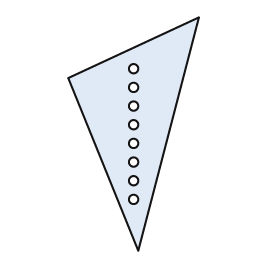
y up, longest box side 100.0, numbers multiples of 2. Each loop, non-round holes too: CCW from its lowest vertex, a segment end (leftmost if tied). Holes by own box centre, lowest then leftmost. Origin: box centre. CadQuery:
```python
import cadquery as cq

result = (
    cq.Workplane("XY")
    .moveTo(2.0, -50.0)
    .lineTo(28.0, 50.0)
    .lineTo(-28.0, 24.0)
    .close()
    .moveTo(0.0, -28.0)
    .circle(2.0)
    .moveTo(0.0, -20.0)
    .circle(2.0)
    .moveTo(0.0, -12.0)
    .circle(2.0)
    .moveTo(0.0, -4.0)
    .circle(2.0)
    .moveTo(0.0, 4.0)
    .circle(2.0)
    .moveTo(0.0, 12.0)
    .circle(2.0)
    .moveTo(0.0, 20.0)
    .circle(2.0)
    .moveTo(0.0, 28.0)
    .circle(2.0)
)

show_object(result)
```